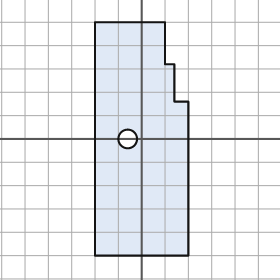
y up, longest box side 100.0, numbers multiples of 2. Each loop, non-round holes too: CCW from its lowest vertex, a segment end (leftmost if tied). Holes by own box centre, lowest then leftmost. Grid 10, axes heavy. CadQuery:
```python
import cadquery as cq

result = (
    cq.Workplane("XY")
    .moveTo(-20.0, -50.0)
    .lineTo(20.0, -50.0)
    .lineTo(20.0, 16.0)
    .lineTo(14.0, 16.0)
    .lineTo(14.0, 32.0)
    .lineTo(10.0, 32.0)
    .lineTo(10.0, 50.0)
    .lineTo(-20.0, 50.0)
    .close()
    .moveTo(-6.0, 0.0)
    .circle(4.0)
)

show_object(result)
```